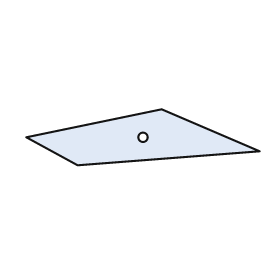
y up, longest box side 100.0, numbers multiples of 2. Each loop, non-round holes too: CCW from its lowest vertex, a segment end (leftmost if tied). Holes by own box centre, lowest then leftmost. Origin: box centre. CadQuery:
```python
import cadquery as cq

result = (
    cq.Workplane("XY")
    .moveTo(-28.0, -12.0)
    .lineTo(50.0, -6.0)
    .lineTo(8.0, 12.0)
    .lineTo(-50.0, 0.0)
    .close()
    .moveTo(0.0, 0.0)
    .circle(2.0)
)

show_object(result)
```